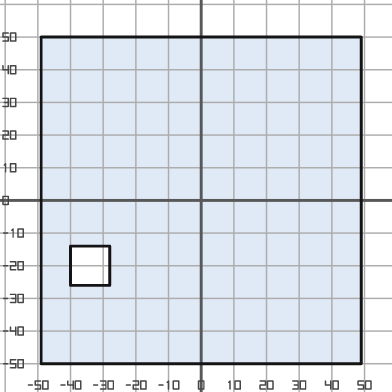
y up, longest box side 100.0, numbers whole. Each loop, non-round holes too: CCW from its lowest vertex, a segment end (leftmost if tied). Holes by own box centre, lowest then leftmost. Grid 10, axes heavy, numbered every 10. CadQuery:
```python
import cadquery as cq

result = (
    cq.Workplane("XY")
    .moveTo(-49.0, -50.0)
    .lineTo(49.0, -50.0)
    .lineTo(49.0, 50.0)
    .lineTo(-49.0, 50.0)
    .close()
    .moveTo(-40.0, -26.0)
    .lineTo(-28.0, -26.0)
    .lineTo(-28.0, -14.0)
    .lineTo(-40.0, -14.0)
    .close()
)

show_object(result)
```